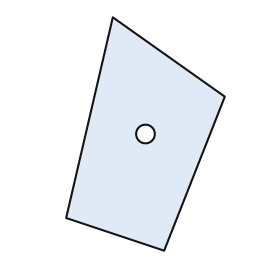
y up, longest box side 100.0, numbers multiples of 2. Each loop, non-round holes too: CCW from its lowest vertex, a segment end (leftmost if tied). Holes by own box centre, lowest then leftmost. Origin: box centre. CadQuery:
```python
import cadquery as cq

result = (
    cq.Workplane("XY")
    .moveTo(8.0, -50.0)
    .lineTo(34.0, 16.0)
    .lineTo(-14.0, 50.0)
    .lineTo(-34.0, -36.0)
    .close()
    .moveTo(0.0, 0.0)
    .circle(4.0)
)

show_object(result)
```